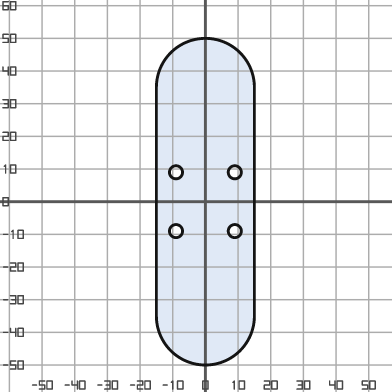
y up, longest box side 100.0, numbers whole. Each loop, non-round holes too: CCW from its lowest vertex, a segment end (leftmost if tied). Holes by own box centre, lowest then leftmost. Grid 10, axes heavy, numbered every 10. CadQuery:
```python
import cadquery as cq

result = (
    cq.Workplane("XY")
    .moveTo(-15.0, -35.0)
    .threePointArc((0.0, -50.0), (15.0, -35.0))
    .lineTo(15.0, 35.0)
    .threePointArc((0.0, 50.0), (-15.0, 35.0))
    .close()
    .moveTo(-9.0, -9.0)
    .circle(2.0)
    .moveTo(9.0, -9.0)
    .circle(2.0)
    .moveTo(-9.0, 9.0)
    .circle(2.0)
    .moveTo(9.0, 9.0)
    .circle(2.0)
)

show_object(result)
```